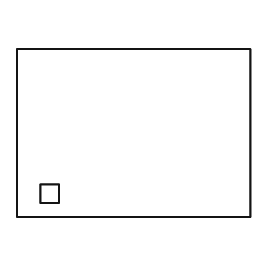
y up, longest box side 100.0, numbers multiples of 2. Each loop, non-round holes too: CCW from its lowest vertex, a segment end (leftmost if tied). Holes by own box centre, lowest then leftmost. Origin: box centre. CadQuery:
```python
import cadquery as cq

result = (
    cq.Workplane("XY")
    .moveTo(-50.0, -36.0)
    .lineTo(50.0, -36.0)
    .lineTo(50.0, 36.0)
    .lineTo(-50.0, 36.0)
    .close()
    .moveTo(-40.0, -30.0)
    .lineTo(-32.0, -30.0)
    .lineTo(-32.0, -22.0)
    .lineTo(-40.0, -22.0)
    .close()
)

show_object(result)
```